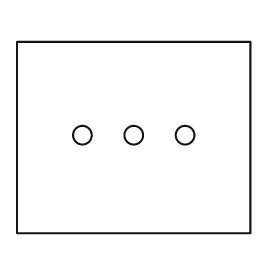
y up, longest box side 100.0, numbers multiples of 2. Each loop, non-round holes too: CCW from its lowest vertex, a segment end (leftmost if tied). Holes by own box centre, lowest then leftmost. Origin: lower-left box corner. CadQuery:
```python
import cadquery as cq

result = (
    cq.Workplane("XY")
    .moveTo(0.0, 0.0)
    .lineTo(100.0, 0.0)
    .lineTo(100.0, 82.0)
    .lineTo(0.0, 82.0)
    .close()
    .moveTo(28.0, 42.0)
    .circle(4.0)
    .moveTo(50.0, 42.0)
    .circle(4.0)
    .moveTo(72.0, 42.0)
    .circle(4.0)
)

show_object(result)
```